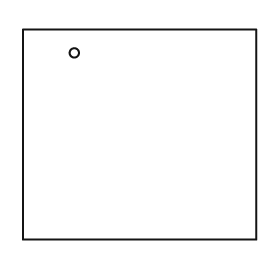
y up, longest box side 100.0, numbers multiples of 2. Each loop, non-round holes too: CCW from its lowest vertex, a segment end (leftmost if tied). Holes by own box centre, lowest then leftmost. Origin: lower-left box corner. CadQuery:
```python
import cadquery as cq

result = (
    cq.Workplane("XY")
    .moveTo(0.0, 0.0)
    .lineTo(100.0, 0.0)
    .lineTo(100.0, 90.0)
    .lineTo(0.0, 90.0)
    .close()
    .moveTo(22.0, 80.0)
    .circle(2.0)
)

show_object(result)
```